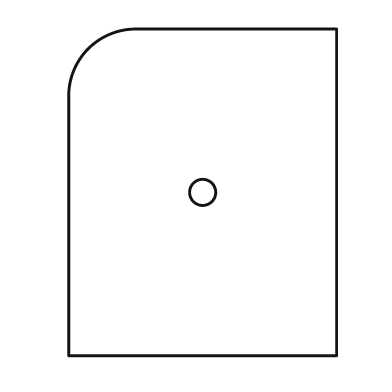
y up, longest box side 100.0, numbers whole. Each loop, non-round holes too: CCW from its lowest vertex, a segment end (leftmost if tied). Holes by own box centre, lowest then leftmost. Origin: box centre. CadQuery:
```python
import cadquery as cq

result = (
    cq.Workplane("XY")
    .moveTo(-41.0, -50.0)
    .lineTo(41.0, -50.0)
    .lineTo(41.0, 50.0)
    .lineTo(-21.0, 50.0)
    .threePointArc((-35.0, 44.0), (-41.0, 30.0))
    .close()
    .moveTo(0.0, 0.0)
    .circle(4.0)
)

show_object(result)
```